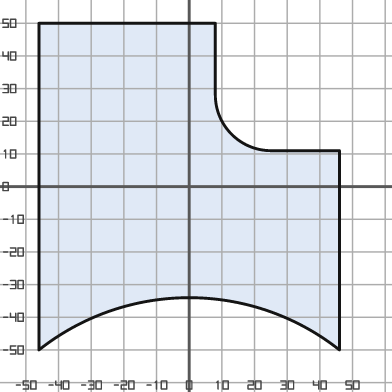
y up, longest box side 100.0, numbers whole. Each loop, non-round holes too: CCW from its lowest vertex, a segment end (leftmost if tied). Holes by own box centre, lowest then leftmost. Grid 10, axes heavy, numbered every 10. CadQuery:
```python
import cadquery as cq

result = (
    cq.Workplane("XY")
    .moveTo(-46.0, -50.0)
    .threePointArc((0.0, -34.0), (46.0, -50.0))
    .lineTo(46.0, 11.0)
    .lineTo(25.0, 11.0)
    .threePointArc((13.0, 16.0), (8.0, 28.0))
    .lineTo(8.0, 50.0)
    .lineTo(-46.0, 50.0)
    .close()
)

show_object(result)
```